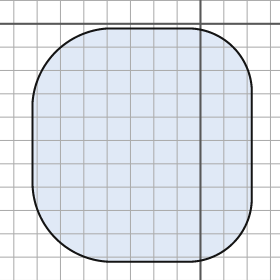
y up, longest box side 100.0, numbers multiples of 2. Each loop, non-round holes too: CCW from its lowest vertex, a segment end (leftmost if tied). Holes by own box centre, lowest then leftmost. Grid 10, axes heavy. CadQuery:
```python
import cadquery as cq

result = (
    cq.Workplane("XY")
    .moveTo(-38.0, -102.0)
    .lineTo(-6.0, -102.0)
    .threePointArc((14.0, -94.0), (22.0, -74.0))
    .lineTo(22.0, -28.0)
    .threePointArc((14.0, -10.0), (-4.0, -2.0))
    .lineTo(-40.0, -2.0)
    .threePointArc((-62.0, -12.0), (-72.0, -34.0))
    .lineTo(-72.0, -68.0)
    .threePointArc((-62.0, -92.0), (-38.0, -102.0))
    .close()
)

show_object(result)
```